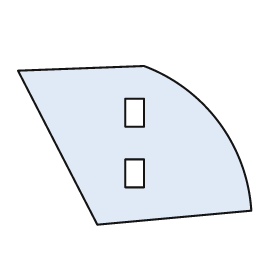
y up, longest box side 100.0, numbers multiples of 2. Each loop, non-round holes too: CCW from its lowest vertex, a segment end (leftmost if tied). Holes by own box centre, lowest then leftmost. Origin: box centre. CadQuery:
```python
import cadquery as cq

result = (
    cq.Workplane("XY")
    .moveTo(-16.0, -34.0)
    .lineTo(50.0, -28.0)
    .threePointArc((36.0, 10.0), (4.0, 34.0))
    .lineTo(-50.0, 32.0)
    .close()
    .moveTo(-4.0, -18.0)
    .lineTo(4.0, -18.0)
    .lineTo(4.0, -6.0)
    .lineTo(-4.0, -6.0)
    .close()
    .moveTo(-4.0, 8.0)
    .lineTo(4.0, 8.0)
    .lineTo(4.0, 20.0)
    .lineTo(-4.0, 20.0)
    .close()
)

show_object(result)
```